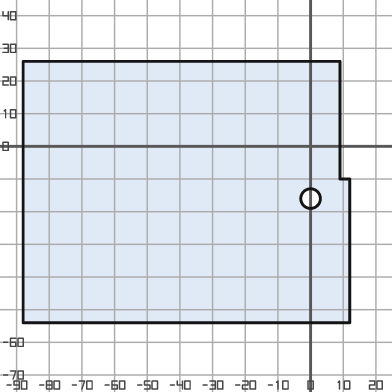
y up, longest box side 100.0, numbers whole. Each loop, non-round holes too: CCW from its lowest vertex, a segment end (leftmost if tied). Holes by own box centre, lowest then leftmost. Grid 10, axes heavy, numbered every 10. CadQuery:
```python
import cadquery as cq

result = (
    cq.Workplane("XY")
    .moveTo(-88.0, -54.0)
    .lineTo(12.0, -54.0)
    .lineTo(12.0, -10.0)
    .lineTo(9.0, -10.0)
    .lineTo(9.0, 26.0)
    .lineTo(-88.0, 26.0)
    .close()
    .moveTo(0.0, -16.0)
    .circle(3.0)
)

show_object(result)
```